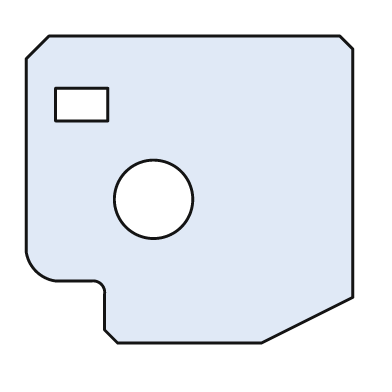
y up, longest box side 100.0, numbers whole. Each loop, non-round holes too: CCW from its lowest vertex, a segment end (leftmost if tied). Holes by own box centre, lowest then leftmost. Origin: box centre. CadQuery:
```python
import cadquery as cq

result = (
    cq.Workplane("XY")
    .moveTo(-22.0, -47.0)
    .lineTo(22.0, -47.0)
    .lineTo(50.0, -33.0)
    .lineTo(50.0, 43.0)
    .lineTo(46.0, 47.0)
    .lineTo(-43.0, 47.0)
    .lineTo(-50.0, 40.0)
    .lineTo(-50.0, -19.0)
    .threePointArc((-47.0, -25.0), (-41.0, -28.0))
    .lineTo(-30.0, -28.0)
    .threePointArc((-27.0, -29.0), (-26.0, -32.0))
    .lineTo(-26.0, -43.0)
    .close()
    .moveTo(-11.0, -3.0)
    .circle(12.0)
    .moveTo(-41.0, 21.0)
    .lineTo(-25.0, 21.0)
    .lineTo(-25.0, 31.0)
    .lineTo(-41.0, 31.0)
    .close()
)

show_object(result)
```